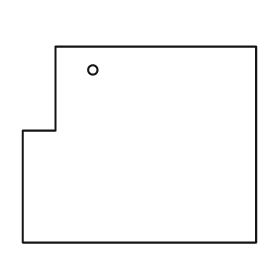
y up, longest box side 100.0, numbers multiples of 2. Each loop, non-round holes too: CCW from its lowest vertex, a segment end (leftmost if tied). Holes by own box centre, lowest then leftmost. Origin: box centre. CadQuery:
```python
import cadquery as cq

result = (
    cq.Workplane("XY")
    .moveTo(-50.0, -42.0)
    .lineTo(50.0, -42.0)
    .lineTo(50.0, 42.0)
    .lineTo(-36.0, 42.0)
    .lineTo(-36.0, 6.0)
    .lineTo(-50.0, 6.0)
    .close()
    .moveTo(-20.0, 32.0)
    .circle(2.0)
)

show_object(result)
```